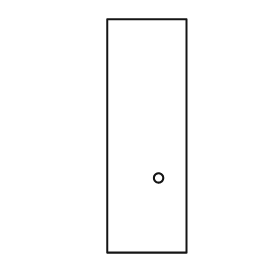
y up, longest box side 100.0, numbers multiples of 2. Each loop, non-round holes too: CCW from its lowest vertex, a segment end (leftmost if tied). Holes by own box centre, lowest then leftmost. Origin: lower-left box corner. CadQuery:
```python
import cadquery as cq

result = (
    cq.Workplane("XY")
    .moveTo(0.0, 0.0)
    .lineTo(34.0, 0.0)
    .lineTo(34.0, 100.0)
    .lineTo(0.0, 100.0)
    .close()
    .moveTo(22.0, 32.0)
    .circle(2.0)
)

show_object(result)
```